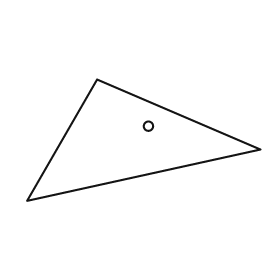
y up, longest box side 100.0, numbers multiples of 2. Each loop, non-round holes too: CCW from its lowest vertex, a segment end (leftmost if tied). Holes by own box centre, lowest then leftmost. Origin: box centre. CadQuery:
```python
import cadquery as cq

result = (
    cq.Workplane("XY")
    .moveTo(-50.0, -26.0)
    .lineTo(50.0, -4.0)
    .lineTo(-20.0, 26.0)
    .close()
    .moveTo(2.0, 6.0)
    .circle(2.0)
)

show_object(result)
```